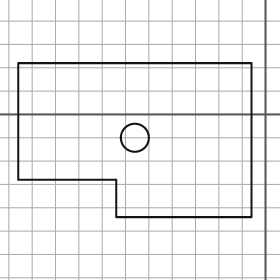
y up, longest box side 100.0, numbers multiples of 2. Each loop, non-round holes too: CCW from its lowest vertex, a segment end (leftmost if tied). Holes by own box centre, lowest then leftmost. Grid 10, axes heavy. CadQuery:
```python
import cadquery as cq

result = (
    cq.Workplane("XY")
    .moveTo(-64.0, -44.0)
    .lineTo(-6.0, -44.0)
    .lineTo(-6.0, 22.0)
    .lineTo(-106.0, 22.0)
    .lineTo(-106.0, -28.0)
    .lineTo(-64.0, -28.0)
    .close()
    .moveTo(-56.0, -10.0)
    .circle(6.0)
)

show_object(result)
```